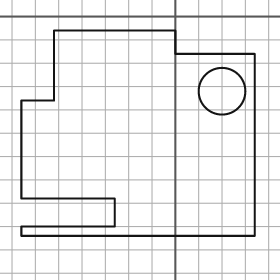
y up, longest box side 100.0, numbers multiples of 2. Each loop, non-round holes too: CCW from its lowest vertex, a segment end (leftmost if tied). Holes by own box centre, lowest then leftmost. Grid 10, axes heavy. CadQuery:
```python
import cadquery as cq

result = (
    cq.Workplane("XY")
    .moveTo(-66.0, -94.0)
    .lineTo(34.0, -94.0)
    .lineTo(34.0, -16.0)
    .lineTo(0.0, -16.0)
    .lineTo(0.0, -6.0)
    .lineTo(-52.0, -6.0)
    .lineTo(-52.0, -36.0)
    .lineTo(-66.0, -36.0)
    .lineTo(-66.0, -78.0)
    .lineTo(-26.0, -78.0)
    .lineTo(-26.0, -90.0)
    .lineTo(-66.0, -90.0)
    .close()
    .moveTo(20.0, -32.0)
    .circle(10.0)
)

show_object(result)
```